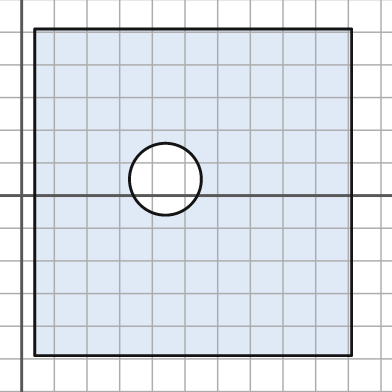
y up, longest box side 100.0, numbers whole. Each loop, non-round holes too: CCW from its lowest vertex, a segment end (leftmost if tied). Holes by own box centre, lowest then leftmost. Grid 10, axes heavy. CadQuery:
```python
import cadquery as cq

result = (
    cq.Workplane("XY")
    .moveTo(4.0, -49.0)
    .lineTo(101.0, -49.0)
    .lineTo(101.0, 51.0)
    .lineTo(4.0, 51.0)
    .close()
    .moveTo(44.0, 5.0)
    .circle(11.0)
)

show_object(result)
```